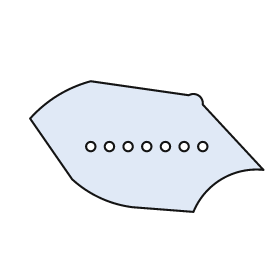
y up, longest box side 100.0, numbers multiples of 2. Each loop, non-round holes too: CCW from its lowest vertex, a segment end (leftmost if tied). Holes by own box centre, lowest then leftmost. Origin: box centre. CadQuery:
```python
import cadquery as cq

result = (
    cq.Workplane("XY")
    .moveTo(20.0, -28.0)
    .threePointArc((32.0, -14.0), (50.0, -10.0))
    .lineTo(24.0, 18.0)
    .threePointArc((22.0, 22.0), (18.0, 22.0))
    .lineTo(-24.0, 28.0)
    .threePointArc((-38.0, 22.0), (-50.0, 12.0))
    .lineTo(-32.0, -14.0)
    .threePointArc((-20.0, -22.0), (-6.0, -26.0))
    .close()
    .moveTo(-24.0, 0.0)
    .circle(2.0)
    .moveTo(-16.0, 0.0)
    .circle(2.0)
    .moveTo(-8.0, 0.0)
    .circle(2.0)
    .moveTo(0.0, 0.0)
    .circle(2.0)
    .moveTo(8.0, 0.0)
    .circle(2.0)
    .moveTo(16.0, 0.0)
    .circle(2.0)
    .moveTo(24.0, 0.0)
    .circle(2.0)
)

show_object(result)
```